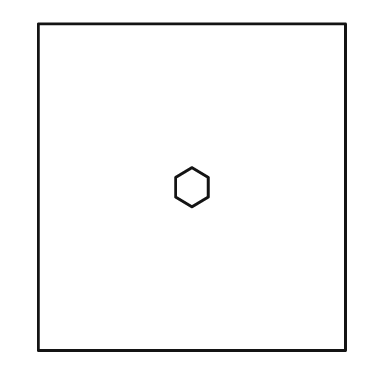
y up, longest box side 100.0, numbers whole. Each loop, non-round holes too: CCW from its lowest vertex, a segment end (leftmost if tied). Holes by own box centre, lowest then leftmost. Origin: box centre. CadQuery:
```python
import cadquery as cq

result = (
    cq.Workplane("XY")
    .moveTo(-47.0, -50.0)
    .lineTo(47.0, -50.0)
    .lineTo(47.0, 50.0)
    .lineTo(-47.0, 50.0)
    .close()
    .moveTo(0.0, -6.0)
    .lineTo(5.0, -3.0)
    .lineTo(5.0, 3.0)
    .lineTo(0.0, 6.0)
    .lineTo(-5.0, 3.0)
    .lineTo(-5.0, -3.0)
    .close()
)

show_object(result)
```